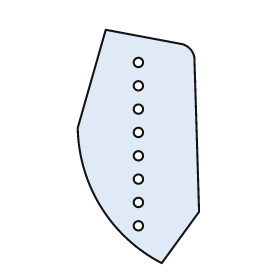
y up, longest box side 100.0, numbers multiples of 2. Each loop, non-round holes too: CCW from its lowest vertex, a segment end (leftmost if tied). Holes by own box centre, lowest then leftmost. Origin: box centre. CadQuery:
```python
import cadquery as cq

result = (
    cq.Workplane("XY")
    .moveTo(10.0, -50.0)
    .lineTo(26.0, -28.0)
    .lineTo(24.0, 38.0)
    .threePointArc((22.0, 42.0), (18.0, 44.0))
    .lineTo(-14.0, 50.0)
    .lineTo(-26.0, 8.0)
    .threePointArc((-16.0, -26.0), (10.0, -50.0))
    .close()
    .moveTo(0.0, -34.0)
    .circle(2.0)
    .moveTo(0.0, -24.0)
    .circle(2.0)
    .moveTo(0.0, -14.0)
    .circle(2.0)
    .moveTo(0.0, -4.0)
    .circle(2.0)
    .moveTo(0.0, 6.0)
    .circle(2.0)
    .moveTo(0.0, 16.0)
    .circle(2.0)
    .moveTo(0.0, 26.0)
    .circle(2.0)
    .moveTo(0.0, 36.0)
    .circle(2.0)
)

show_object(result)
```